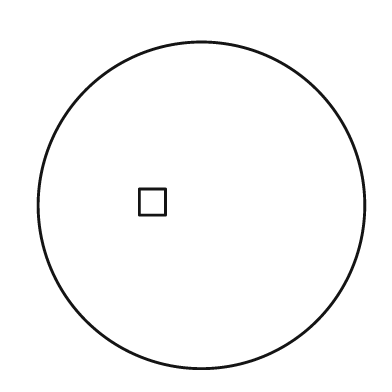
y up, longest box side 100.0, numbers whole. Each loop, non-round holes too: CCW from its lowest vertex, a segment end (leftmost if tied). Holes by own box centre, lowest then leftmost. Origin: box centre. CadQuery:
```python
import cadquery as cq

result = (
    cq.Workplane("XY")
    .moveTo(0.0, 0.0)
    .circle(50.0)
    .moveTo(-19.0, -3.0)
    .lineTo(-11.0, -3.0)
    .lineTo(-11.0, 5.0)
    .lineTo(-19.0, 5.0)
    .close()
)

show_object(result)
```